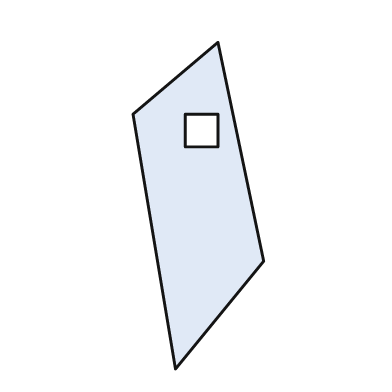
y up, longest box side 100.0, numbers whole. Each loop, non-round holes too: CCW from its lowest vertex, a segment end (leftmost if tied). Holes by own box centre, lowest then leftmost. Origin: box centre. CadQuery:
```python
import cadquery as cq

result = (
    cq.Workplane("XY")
    .moveTo(-7.0, -50.0)
    .lineTo(20.0, -17.0)
    .lineTo(6.0, 50.0)
    .lineTo(-20.0, 28.0)
    .close()
    .moveTo(-4.0, 18.0)
    .lineTo(6.0, 18.0)
    .lineTo(6.0, 28.0)
    .lineTo(-4.0, 28.0)
    .close()
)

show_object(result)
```